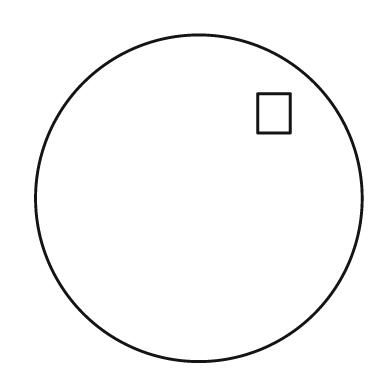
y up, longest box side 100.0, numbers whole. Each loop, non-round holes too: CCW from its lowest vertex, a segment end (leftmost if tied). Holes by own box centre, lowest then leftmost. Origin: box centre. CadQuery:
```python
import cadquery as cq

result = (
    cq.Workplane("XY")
    .moveTo(0.0, 0.0)
    .circle(50.0)
    .moveTo(18.0, 20.0)
    .lineTo(28.0, 20.0)
    .lineTo(28.0, 32.0)
    .lineTo(18.0, 32.0)
    .close()
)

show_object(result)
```